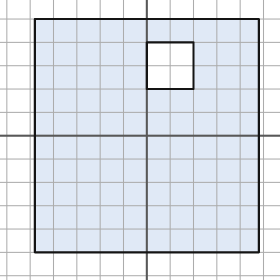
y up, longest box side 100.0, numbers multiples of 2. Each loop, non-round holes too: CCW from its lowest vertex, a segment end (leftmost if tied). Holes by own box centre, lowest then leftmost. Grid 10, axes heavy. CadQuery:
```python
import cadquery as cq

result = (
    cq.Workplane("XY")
    .moveTo(-48.0, -50.0)
    .lineTo(48.0, -50.0)
    .lineTo(48.0, 50.0)
    .lineTo(-48.0, 50.0)
    .close()
    .moveTo(0.0, 20.0)
    .lineTo(20.0, 20.0)
    .lineTo(20.0, 40.0)
    .lineTo(0.0, 40.0)
    .close()
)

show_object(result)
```